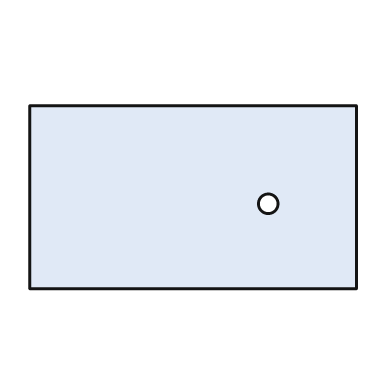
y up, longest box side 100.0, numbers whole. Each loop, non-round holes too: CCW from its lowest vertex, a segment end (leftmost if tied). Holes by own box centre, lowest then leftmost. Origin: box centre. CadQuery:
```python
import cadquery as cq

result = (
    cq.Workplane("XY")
    .moveTo(-50.0, -28.0)
    .lineTo(50.0, -28.0)
    .lineTo(50.0, 28.0)
    .lineTo(-50.0, 28.0)
    .close()
    .moveTo(23.0, -2.0)
    .circle(3.0)
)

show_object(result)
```